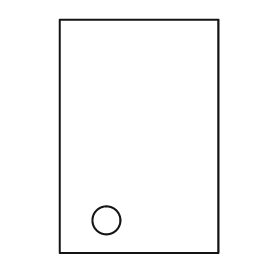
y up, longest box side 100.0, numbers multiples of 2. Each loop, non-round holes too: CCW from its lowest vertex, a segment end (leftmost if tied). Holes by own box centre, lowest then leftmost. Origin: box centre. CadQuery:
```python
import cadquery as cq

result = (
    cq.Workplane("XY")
    .moveTo(-34.0, -50.0)
    .lineTo(34.0, -50.0)
    .lineTo(34.0, 50.0)
    .lineTo(-34.0, 50.0)
    .close()
    .moveTo(-14.0, -36.0)
    .circle(6.0)
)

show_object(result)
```